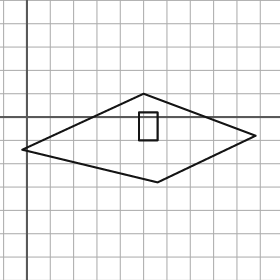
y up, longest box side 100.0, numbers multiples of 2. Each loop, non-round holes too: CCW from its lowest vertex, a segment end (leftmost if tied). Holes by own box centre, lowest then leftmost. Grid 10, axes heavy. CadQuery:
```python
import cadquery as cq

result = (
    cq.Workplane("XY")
    .moveTo(56.0, -28.0)
    .lineTo(98.0, -8.0)
    .lineTo(50.0, 10.0)
    .lineTo(-2.0, -14.0)
    .close()
    .moveTo(48.0, -10.0)
    .lineTo(56.0, -10.0)
    .lineTo(56.0, 2.0)
    .lineTo(48.0, 2.0)
    .close()
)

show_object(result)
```